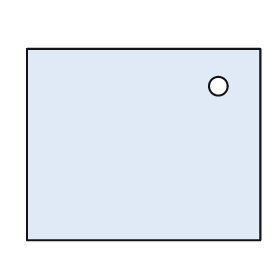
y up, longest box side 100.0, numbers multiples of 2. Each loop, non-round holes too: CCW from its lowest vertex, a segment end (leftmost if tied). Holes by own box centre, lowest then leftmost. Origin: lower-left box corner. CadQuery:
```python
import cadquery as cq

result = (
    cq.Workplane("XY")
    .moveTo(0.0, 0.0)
    .lineTo(100.0, 0.0)
    .lineTo(100.0, 82.0)
    .lineTo(0.0, 82.0)
    .close()
    .moveTo(82.0, 66.0)
    .circle(4.0)
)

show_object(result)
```